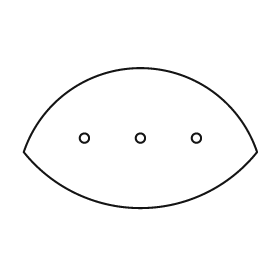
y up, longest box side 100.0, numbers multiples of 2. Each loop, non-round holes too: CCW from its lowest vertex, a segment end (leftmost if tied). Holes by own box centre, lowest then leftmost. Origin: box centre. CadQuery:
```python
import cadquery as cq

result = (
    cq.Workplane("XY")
    .moveTo(-50.0, -6.0)
    .threePointArc((0.0, -30.0), (50.0, -6.0))
    .threePointArc((0.0, 30.0), (-50.0, -6.0))
    .close()
    .moveTo(-24.0, 0.0)
    .circle(2.0)
    .moveTo(0.0, 0.0)
    .circle(2.0)
    .moveTo(24.0, 0.0)
    .circle(2.0)
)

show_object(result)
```